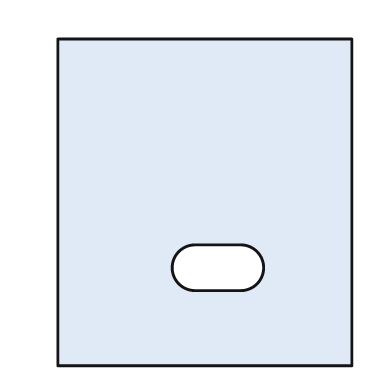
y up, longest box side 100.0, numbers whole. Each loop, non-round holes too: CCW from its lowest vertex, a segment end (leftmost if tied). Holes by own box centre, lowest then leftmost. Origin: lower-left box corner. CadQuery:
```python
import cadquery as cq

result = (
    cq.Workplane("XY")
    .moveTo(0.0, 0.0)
    .lineTo(90.0, 0.0)
    .lineTo(90.0, 100.0)
    .lineTo(0.0, 100.0)
    .close()
    .moveTo(42.0, 23.0)
    .lineTo(56.0, 23.0)
    .threePointArc((63.0, 30.0), (56.0, 37.0))
    .lineTo(42.0, 37.0)
    .threePointArc((35.0, 30.0), (42.0, 23.0))
    .close()
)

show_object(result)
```